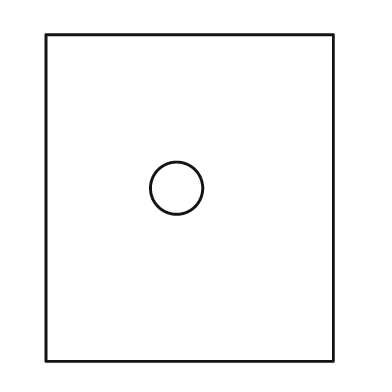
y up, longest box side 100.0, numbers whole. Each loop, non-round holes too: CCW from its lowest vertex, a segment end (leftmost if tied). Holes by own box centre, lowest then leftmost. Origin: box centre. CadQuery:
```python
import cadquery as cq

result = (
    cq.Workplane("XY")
    .moveTo(-44.0, -50.0)
    .lineTo(44.0, -50.0)
    .lineTo(44.0, 50.0)
    .lineTo(-44.0, 50.0)
    .close()
    .moveTo(-4.0, 3.0)
    .circle(8.0)
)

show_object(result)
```